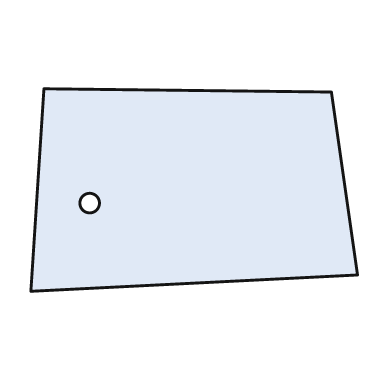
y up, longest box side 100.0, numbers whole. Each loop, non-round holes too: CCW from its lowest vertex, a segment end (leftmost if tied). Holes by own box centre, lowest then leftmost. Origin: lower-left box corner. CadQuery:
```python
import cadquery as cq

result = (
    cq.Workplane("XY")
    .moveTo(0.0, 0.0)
    .lineTo(100.0, 5.0)
    .lineTo(92.0, 61.0)
    .lineTo(4.0, 62.0)
    .close()
    .moveTo(18.0, 27.0)
    .circle(3.0)
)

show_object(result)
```